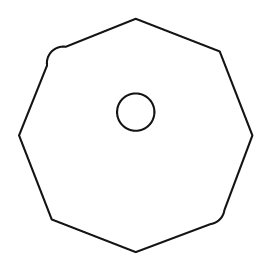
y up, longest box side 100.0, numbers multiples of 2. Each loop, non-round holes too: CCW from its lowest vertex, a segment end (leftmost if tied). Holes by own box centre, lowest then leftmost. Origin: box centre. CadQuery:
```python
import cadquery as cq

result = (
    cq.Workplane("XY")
    .moveTo(0.0, -50.0)
    .lineTo(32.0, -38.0)
    .threePointArc((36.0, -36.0), (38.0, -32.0))
    .lineTo(50.0, 0.0)
    .lineTo(36.0, 36.0)
    .lineTo(0.0, 50.0)
    .lineTo(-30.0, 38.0)
    .threePointArc((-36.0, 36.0), (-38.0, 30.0))
    .lineTo(-50.0, 0.0)
    .lineTo(-36.0, -36.0)
    .close()
    .moveTo(0.0, 10.0)
    .circle(8.0)
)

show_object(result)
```